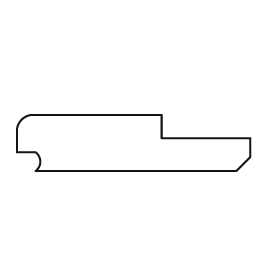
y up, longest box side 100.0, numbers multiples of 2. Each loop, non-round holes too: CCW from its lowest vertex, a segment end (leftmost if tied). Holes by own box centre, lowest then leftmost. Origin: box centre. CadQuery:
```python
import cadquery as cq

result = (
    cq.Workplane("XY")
    .moveTo(-42.0, -12.0)
    .lineTo(44.0, -12.0)
    .lineTo(50.0, -6.0)
    .lineTo(50.0, 2.0)
    .lineTo(12.0, 2.0)
    .lineTo(12.0, 12.0)
    .lineTo(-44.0, 12.0)
    .threePointArc((-48.0, 10.0), (-50.0, 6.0))
    .lineTo(-50.0, -4.0)
    .lineTo(-42.0, -4.0)
    .threePointArc((-40.0, -8.0), (-42.0, -12.0))
    .close()
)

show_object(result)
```